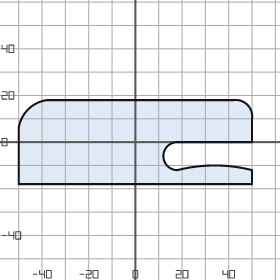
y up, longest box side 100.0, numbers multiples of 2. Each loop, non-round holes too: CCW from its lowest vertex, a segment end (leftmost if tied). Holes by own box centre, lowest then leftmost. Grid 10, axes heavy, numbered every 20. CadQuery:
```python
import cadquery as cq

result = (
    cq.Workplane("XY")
    .moveTo(-50.0, -18.0)
    .lineTo(50.0, -18.0)
    .lineTo(50.0, -12.0)
    .threePointArc((34.0, -10.0), (18.0, -12.0))
    .threePointArc((12.0, -6.0), (18.0, 0.0))
    .lineTo(50.0, 0.0)
    .lineTo(50.0, 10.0)
    .threePointArc((48.0, 16.0), (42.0, 18.0))
    .lineTo(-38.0, 18.0)
    .threePointArc((-46.0, 14.0), (-50.0, 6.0))
    .close()
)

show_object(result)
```